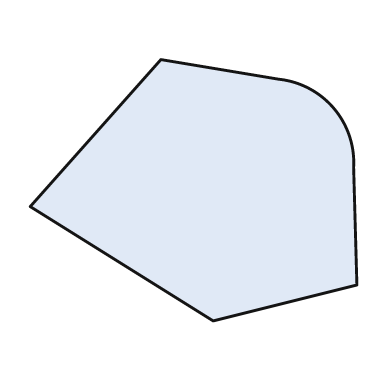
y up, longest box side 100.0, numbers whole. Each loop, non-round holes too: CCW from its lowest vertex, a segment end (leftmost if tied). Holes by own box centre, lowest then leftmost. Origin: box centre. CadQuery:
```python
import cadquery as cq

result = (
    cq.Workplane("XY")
    .moveTo(6.0, -40.0)
    .lineTo(50.0, -29.0)
    .lineTo(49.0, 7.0)
    .threePointArc((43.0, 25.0), (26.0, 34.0))
    .lineTo(-10.0, 40.0)
    .lineTo(-50.0, -5.0)
    .close()
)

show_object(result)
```